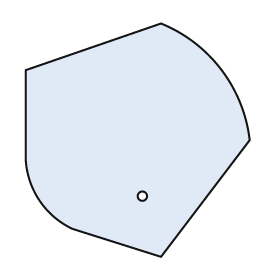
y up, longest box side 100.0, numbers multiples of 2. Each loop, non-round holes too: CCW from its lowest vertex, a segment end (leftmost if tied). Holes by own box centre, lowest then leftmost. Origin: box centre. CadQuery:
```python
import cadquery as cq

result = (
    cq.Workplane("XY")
    .moveTo(10.0, -50.0)
    .lineTo(48.0, 0.0)
    .threePointArc((36.0, 30.0), (10.0, 50.0))
    .lineTo(-48.0, 30.0)
    .lineTo(-48.0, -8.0)
    .threePointArc((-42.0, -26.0), (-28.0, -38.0))
    .close()
    .moveTo(2.0, -24.0)
    .circle(2.0)
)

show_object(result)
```